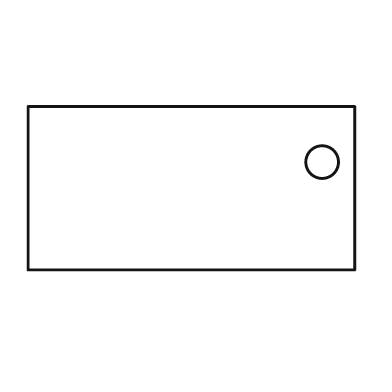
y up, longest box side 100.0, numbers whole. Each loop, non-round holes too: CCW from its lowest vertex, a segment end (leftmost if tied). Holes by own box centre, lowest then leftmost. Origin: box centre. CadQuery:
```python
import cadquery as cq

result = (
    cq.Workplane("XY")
    .moveTo(-50.0, -25.0)
    .lineTo(50.0, -25.0)
    .lineTo(50.0, 25.0)
    .lineTo(-50.0, 25.0)
    .close()
    .moveTo(40.0, 8.0)
    .circle(5.0)
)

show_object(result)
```